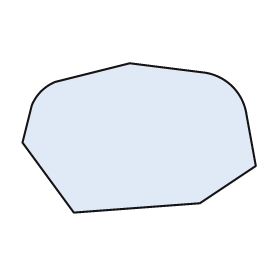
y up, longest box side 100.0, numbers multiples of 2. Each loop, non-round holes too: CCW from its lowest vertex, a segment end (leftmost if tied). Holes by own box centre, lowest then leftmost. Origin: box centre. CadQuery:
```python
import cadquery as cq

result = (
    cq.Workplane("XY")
    .moveTo(-28.0, -32.0)
    .lineTo(26.0, -28.0)
    .lineTo(50.0, -12.0)
    .lineTo(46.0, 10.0)
    .threePointArc((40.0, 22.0), (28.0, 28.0))
    .lineTo(-4.0, 32.0)
    .lineTo(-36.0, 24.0)
    .threePointArc((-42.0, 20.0), (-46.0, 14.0))
    .lineTo(-50.0, -2.0)
    .close()
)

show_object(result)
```